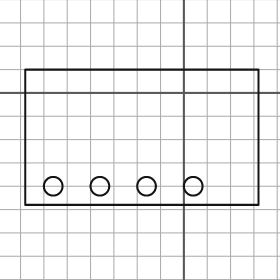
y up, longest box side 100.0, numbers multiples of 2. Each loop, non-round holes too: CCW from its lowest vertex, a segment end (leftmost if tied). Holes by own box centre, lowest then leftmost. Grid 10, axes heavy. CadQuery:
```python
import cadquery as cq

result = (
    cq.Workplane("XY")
    .moveTo(-68.0, -48.0)
    .lineTo(32.0, -48.0)
    .lineTo(32.0, 10.0)
    .lineTo(-68.0, 10.0)
    .close()
    .moveTo(-56.0, -40.0)
    .circle(4.0)
    .moveTo(-36.0, -40.0)
    .circle(4.0)
    .moveTo(-16.0, -40.0)
    .circle(4.0)
    .moveTo(4.0, -40.0)
    .circle(4.0)
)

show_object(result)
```